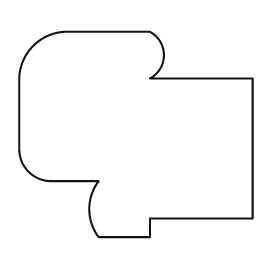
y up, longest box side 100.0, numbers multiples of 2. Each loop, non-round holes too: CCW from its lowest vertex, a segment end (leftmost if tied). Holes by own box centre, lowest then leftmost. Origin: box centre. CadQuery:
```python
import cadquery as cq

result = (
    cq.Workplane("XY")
    .moveTo(-16.0, -44.0)
    .lineTo(6.0, -44.0)
    .lineTo(6.0, -36.0)
    .lineTo(50.0, -36.0)
    .lineTo(50.0, 24.0)
    .lineTo(6.0, 24.0)
    .threePointArc((12.0, 34.0), (6.0, 44.0))
    .lineTo(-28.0, 44.0)
    .threePointArc((-44.0, 38.0), (-50.0, 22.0))
    .lineTo(-50.0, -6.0)
    .threePointArc((-46.0, -16.0), (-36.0, -20.0))
    .lineTo(-16.0, -20.0)
    .threePointArc((-20.0, -32.0), (-16.0, -44.0))
    .close()
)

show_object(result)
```